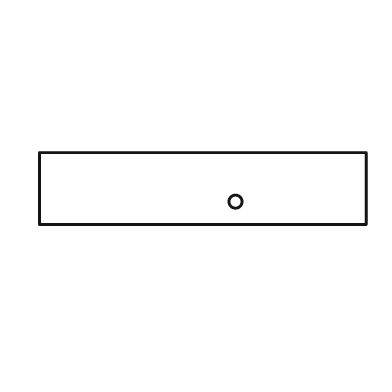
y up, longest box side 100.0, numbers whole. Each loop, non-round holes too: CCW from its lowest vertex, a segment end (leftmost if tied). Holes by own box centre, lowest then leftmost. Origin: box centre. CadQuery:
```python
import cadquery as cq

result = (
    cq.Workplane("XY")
    .moveTo(-50.0, -11.0)
    .lineTo(50.0, -11.0)
    .lineTo(50.0, 11.0)
    .lineTo(-50.0, 11.0)
    .close()
    .moveTo(10.0, -4.0)
    .circle(2.0)
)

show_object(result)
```